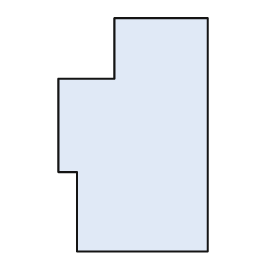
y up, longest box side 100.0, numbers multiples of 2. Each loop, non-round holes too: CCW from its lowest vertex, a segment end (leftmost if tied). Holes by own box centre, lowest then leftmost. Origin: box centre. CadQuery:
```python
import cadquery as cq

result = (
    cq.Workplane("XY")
    .moveTo(-24.0, -50.0)
    .lineTo(32.0, -50.0)
    .lineTo(32.0, 50.0)
    .lineTo(-8.0, 50.0)
    .lineTo(-8.0, 24.0)
    .lineTo(-32.0, 24.0)
    .lineTo(-32.0, -16.0)
    .lineTo(-24.0, -16.0)
    .close()
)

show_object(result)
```